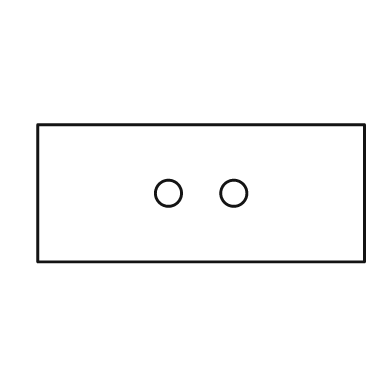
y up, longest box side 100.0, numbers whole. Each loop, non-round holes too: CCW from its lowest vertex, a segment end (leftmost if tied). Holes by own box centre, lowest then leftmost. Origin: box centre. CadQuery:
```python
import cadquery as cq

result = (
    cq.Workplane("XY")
    .moveTo(-50.0, -21.0)
    .lineTo(50.0, -21.0)
    .lineTo(50.0, 21.0)
    .lineTo(-50.0, 21.0)
    .close()
    .moveTo(-10.0, 0.0)
    .circle(4.0)
    .moveTo(10.0, 0.0)
    .circle(4.0)
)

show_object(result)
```